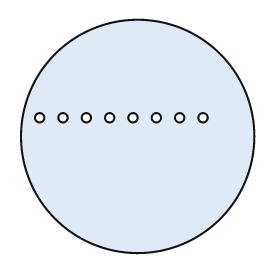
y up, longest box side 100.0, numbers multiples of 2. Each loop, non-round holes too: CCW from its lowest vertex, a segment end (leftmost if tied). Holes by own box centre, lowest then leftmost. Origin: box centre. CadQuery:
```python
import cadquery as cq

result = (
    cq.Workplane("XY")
    .moveTo(0.0, 0.0)
    .circle(50.0)
    .moveTo(-42.0, 8.0)
    .circle(2.0)
    .moveTo(-32.0, 8.0)
    .circle(2.0)
    .moveTo(-22.0, 8.0)
    .circle(2.0)
    .moveTo(-12.0, 8.0)
    .circle(2.0)
    .moveTo(-2.0, 8.0)
    .circle(2.0)
    .moveTo(8.0, 8.0)
    .circle(2.0)
    .moveTo(18.0, 8.0)
    .circle(2.0)
    .moveTo(28.0, 8.0)
    .circle(2.0)
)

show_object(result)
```